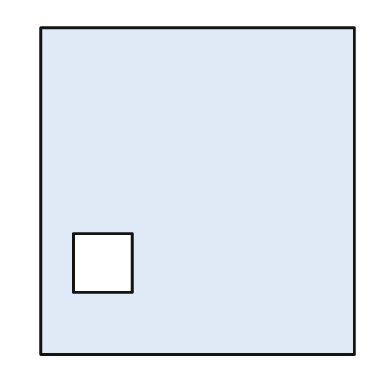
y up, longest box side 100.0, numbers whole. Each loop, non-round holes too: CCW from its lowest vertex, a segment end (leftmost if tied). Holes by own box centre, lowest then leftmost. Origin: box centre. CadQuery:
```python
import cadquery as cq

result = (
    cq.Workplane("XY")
    .moveTo(-48.0, -50.0)
    .lineTo(48.0, -50.0)
    .lineTo(48.0, 50.0)
    .lineTo(-48.0, 50.0)
    .close()
    .moveTo(-38.0, -31.0)
    .lineTo(-20.0, -31.0)
    .lineTo(-20.0, -13.0)
    .lineTo(-38.0, -13.0)
    .close()
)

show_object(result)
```